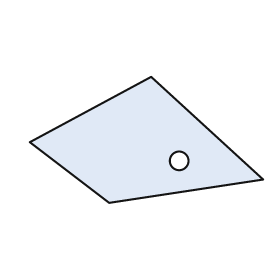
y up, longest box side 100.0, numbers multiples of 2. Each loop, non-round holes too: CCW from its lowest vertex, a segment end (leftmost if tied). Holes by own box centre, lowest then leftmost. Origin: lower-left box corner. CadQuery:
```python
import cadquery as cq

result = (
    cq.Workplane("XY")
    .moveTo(34.0, 0.0)
    .lineTo(100.0, 10.0)
    .lineTo(52.0, 54.0)
    .lineTo(0.0, 26.0)
    .close()
    .moveTo(64.0, 18.0)
    .circle(4.0)
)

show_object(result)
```